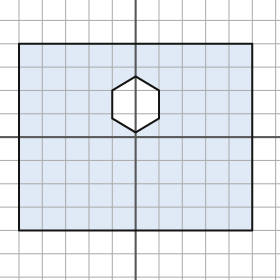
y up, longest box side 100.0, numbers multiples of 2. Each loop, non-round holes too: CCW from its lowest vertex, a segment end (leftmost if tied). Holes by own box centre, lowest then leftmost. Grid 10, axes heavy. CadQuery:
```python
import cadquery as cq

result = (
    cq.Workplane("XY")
    .moveTo(-50.0, -40.0)
    .lineTo(50.0, -40.0)
    .lineTo(50.0, 40.0)
    .lineTo(-50.0, 40.0)
    .close()
    .moveTo(0.0, 2.0)
    .lineTo(10.0, 8.0)
    .lineTo(10.0, 20.0)
    .lineTo(0.0, 26.0)
    .lineTo(-10.0, 20.0)
    .lineTo(-10.0, 8.0)
    .close()
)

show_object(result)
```